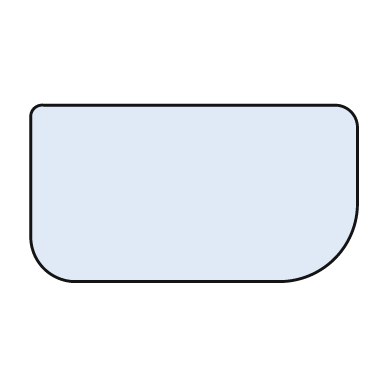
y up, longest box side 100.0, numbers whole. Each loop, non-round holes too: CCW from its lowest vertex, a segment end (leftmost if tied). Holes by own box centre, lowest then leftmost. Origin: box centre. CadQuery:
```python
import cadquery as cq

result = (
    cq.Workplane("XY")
    .moveTo(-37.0, -27.0)
    .lineTo(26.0, -27.0)
    .threePointArc((43.0, -20.0), (50.0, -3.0))
    .lineTo(50.0, 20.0)
    .threePointArc((48.0, 25.0), (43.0, 27.0))
    .lineTo(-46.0, 27.0)
    .threePointArc((-49.0, 26.0), (-50.0, 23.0))
    .lineTo(-50.0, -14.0)
    .threePointArc((-46.0, -23.0), (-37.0, -27.0))
    .close()
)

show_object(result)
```